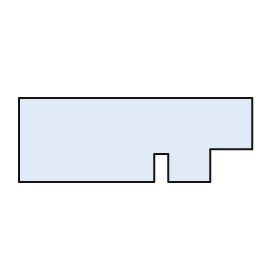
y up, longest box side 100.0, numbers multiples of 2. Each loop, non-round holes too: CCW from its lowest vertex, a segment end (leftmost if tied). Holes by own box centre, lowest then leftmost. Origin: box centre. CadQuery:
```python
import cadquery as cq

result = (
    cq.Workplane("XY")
    .moveTo(-50.0, -18.0)
    .lineTo(8.0, -18.0)
    .lineTo(8.0, -6.0)
    .lineTo(14.0, -6.0)
    .lineTo(14.0, -18.0)
    .lineTo(32.0, -18.0)
    .lineTo(32.0, -4.0)
    .lineTo(50.0, -4.0)
    .lineTo(50.0, 18.0)
    .lineTo(-50.0, 18.0)
    .close()
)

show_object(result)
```